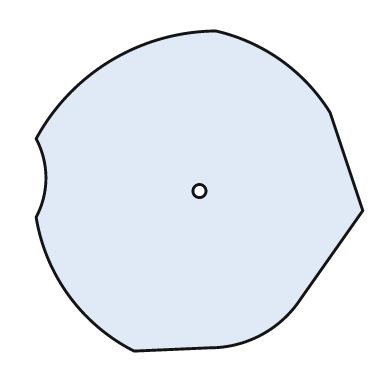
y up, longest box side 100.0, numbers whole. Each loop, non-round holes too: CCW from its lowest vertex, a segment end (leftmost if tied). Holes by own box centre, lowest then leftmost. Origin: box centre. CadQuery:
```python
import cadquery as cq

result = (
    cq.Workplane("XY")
    .moveTo(-20.0, -49.0)
    .lineTo(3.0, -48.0)
    .threePointArc((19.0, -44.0), (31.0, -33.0))
    .lineTo(50.0, -6.0)
    .lineTo(40.0, 24.0)
    .threePointArc((25.0, 40.0), (5.0, 49.0))
    .threePointArc((-27.0, 40.0), (-50.0, 16.0))
    .threePointArc((-47.0, 4.0), (-50.0, -8.0))
    .threePointArc((-40.0, -32.0), (-20.0, -49.0))
    .close()
    .moveTo(0.0, 0.0)
    .circle(2.0)
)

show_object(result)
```